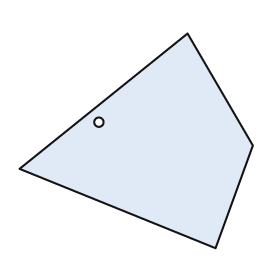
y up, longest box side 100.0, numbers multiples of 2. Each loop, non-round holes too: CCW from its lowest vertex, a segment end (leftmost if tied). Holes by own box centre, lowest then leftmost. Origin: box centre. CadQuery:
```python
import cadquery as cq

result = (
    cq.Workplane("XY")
    .moveTo(34.0, -46.0)
    .lineTo(50.0, -2.0)
    .lineTo(22.0, 46.0)
    .lineTo(-50.0, -12.0)
    .close()
    .moveTo(-16.0, 8.0)
    .circle(2.0)
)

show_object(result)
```